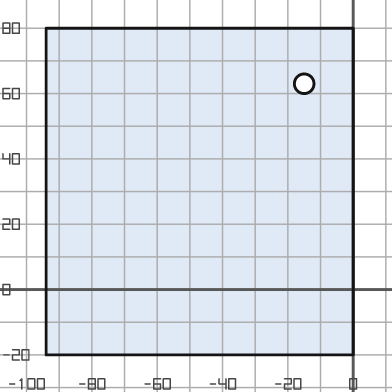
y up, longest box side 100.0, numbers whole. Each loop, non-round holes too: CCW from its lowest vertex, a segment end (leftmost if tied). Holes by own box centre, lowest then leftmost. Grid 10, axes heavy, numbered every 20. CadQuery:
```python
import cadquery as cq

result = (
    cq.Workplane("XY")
    .moveTo(-94.0, -20.0)
    .lineTo(0.0, -20.0)
    .lineTo(0.0, 80.0)
    .lineTo(-94.0, 80.0)
    .close()
    .moveTo(-15.0, 63.0)
    .circle(3.0)
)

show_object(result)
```